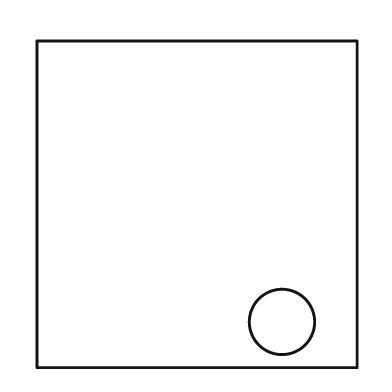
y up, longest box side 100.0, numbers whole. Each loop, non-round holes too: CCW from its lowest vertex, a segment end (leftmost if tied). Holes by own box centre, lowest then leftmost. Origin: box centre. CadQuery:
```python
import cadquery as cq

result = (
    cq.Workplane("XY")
    .moveTo(-49.0, -50.0)
    .lineTo(49.0, -50.0)
    .lineTo(49.0, 50.0)
    .lineTo(-49.0, 50.0)
    .close()
    .moveTo(26.0, -36.0)
    .circle(10.0)
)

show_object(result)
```